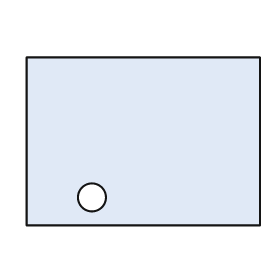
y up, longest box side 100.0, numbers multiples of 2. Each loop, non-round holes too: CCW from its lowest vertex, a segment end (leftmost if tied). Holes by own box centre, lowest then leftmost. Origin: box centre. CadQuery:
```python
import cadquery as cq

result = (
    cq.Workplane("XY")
    .moveTo(-50.0, -36.0)
    .lineTo(50.0, -36.0)
    .lineTo(50.0, 36.0)
    .lineTo(-50.0, 36.0)
    .close()
    .moveTo(-22.0, -24.0)
    .circle(6.0)
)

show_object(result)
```